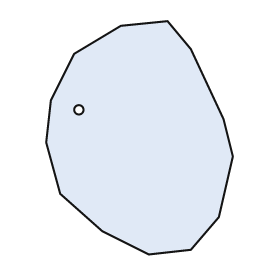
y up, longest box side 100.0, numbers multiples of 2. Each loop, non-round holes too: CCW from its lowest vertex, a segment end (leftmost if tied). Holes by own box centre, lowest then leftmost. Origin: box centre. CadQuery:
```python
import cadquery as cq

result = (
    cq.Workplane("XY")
    .moveTo(4.0, -50.0)
    .lineTo(22.0, -48.0)
    .lineTo(34.0, -34.0)
    .lineTo(40.0, -8.0)
    .lineTo(36.0, 8.0)
    .lineTo(22.0, 38.0)
    .lineTo(12.0, 50.0)
    .lineTo(-8.0, 48.0)
    .lineTo(-28.0, 36.0)
    .lineTo(-38.0, 16.0)
    .lineTo(-40.0, -2.0)
    .lineTo(-34.0, -24.0)
    .lineTo(-16.0, -40.0)
    .close()
    .moveTo(-26.0, 12.0)
    .circle(2.0)
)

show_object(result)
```